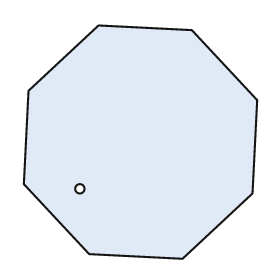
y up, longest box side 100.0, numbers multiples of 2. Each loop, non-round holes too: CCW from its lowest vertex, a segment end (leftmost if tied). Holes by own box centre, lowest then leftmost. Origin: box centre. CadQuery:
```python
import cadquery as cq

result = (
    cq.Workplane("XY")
    .moveTo(18.0, -50.0)
    .lineTo(48.0, -22.0)
    .lineTo(50.0, 18.0)
    .lineTo(22.0, 48.0)
    .lineTo(-18.0, 50.0)
    .lineTo(-48.0, 22.0)
    .lineTo(-50.0, -18.0)
    .lineTo(-22.0, -48.0)
    .close()
    .moveTo(-26.0, -20.0)
    .circle(2.0)
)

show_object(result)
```